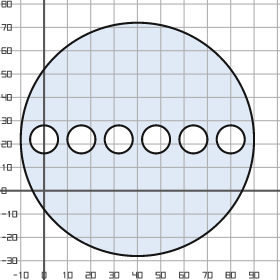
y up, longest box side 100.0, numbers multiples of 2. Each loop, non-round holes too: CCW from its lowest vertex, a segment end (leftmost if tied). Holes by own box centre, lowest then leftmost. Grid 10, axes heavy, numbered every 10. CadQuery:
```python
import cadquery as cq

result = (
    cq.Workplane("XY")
    .moveTo(40.0, 22.0)
    .circle(50.0)
    .moveTo(0.0, 22.0)
    .circle(6.0)
    .moveTo(16.0, 22.0)
    .circle(6.0)
    .moveTo(32.0, 22.0)
    .circle(6.0)
    .moveTo(48.0, 22.0)
    .circle(6.0)
    .moveTo(64.0, 22.0)
    .circle(6.0)
    .moveTo(80.0, 22.0)
    .circle(6.0)
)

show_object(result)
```